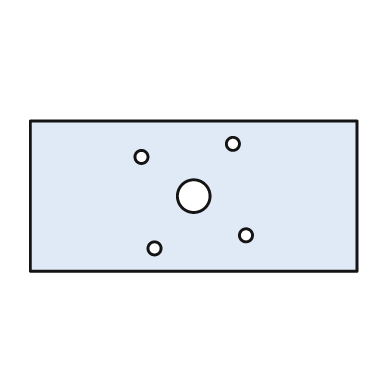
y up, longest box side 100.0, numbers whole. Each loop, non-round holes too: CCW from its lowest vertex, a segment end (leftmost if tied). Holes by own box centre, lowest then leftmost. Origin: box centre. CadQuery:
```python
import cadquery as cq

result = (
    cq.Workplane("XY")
    .moveTo(-50.0, -23.0)
    .lineTo(50.0, -23.0)
    .lineTo(50.0, 23.0)
    .lineTo(-50.0, 23.0)
    .close()
    .moveTo(-12.0, -16.0)
    .circle(2.0)
    .moveTo(16.0, -12.0)
    .circle(2.0)
    .moveTo(0.0, 0.0)
    .circle(5.0)
    .moveTo(-16.0, 12.0)
    .circle(2.0)
    .moveTo(12.0, 16.0)
    .circle(2.0)
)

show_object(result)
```